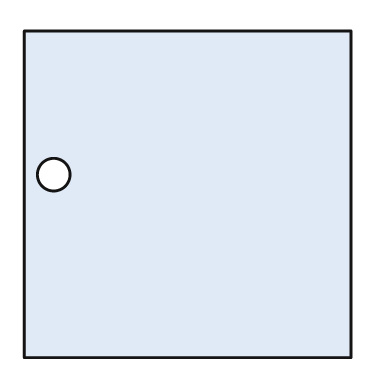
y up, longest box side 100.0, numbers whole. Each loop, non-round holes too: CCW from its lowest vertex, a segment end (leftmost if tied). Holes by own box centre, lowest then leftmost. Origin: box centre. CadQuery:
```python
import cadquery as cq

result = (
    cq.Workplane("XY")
    .moveTo(-50.0, -50.0)
    .lineTo(50.0, -50.0)
    .lineTo(50.0, 50.0)
    .lineTo(-50.0, 50.0)
    .close()
    .moveTo(-41.0, 6.0)
    .circle(5.0)
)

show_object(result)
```